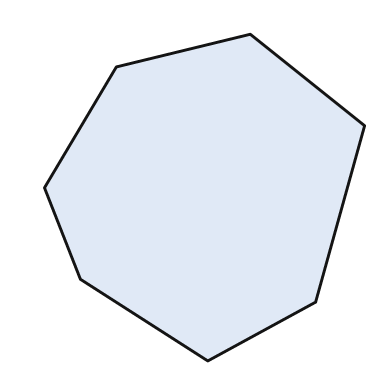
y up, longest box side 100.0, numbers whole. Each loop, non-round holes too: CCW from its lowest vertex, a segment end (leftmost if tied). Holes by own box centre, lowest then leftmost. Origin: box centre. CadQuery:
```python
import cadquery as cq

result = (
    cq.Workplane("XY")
    .moveTo(1.0, -50.0)
    .lineTo(34.0, -32.0)
    .lineTo(49.0, 22.0)
    .lineTo(14.0, 50.0)
    .lineTo(-27.0, 40.0)
    .lineTo(-49.0, 3.0)
    .lineTo(-38.0, -25.0)
    .close()
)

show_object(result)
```